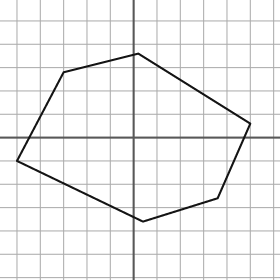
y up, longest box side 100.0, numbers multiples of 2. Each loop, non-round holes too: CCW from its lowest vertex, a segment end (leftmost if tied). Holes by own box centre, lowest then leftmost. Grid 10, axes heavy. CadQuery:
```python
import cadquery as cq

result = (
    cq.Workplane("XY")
    .moveTo(4.0, -36.0)
    .lineTo(36.0, -26.0)
    .lineTo(50.0, 6.0)
    .lineTo(2.0, 36.0)
    .lineTo(-30.0, 28.0)
    .lineTo(-50.0, -10.0)
    .close()
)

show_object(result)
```